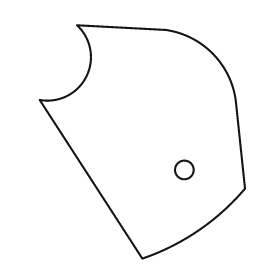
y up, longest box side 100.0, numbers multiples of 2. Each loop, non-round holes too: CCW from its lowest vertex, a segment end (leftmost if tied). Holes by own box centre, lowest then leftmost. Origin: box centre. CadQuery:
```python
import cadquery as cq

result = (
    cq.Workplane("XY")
    .moveTo(0.0, -50.0)
    .threePointArc((24.0, -38.0), (44.0, -20.0))
    .lineTo(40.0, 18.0)
    .threePointArc((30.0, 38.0), (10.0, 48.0))
    .lineTo(-28.0, 50.0)
    .threePointArc((-24.0, 28.0), (-44.0, 18.0))
    .close()
    .moveTo(18.0, -12.0)
    .circle(4.0)
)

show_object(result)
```